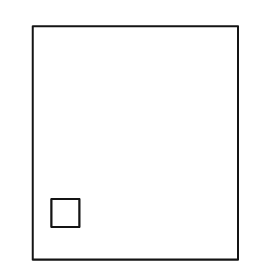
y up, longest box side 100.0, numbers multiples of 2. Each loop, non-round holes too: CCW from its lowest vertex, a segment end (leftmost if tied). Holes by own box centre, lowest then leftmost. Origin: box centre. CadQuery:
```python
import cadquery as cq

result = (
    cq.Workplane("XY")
    .moveTo(-44.0, -50.0)
    .lineTo(44.0, -50.0)
    .lineTo(44.0, 50.0)
    .lineTo(-44.0, 50.0)
    .close()
    .moveTo(-36.0, -36.0)
    .lineTo(-24.0, -36.0)
    .lineTo(-24.0, -24.0)
    .lineTo(-36.0, -24.0)
    .close()
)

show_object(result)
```